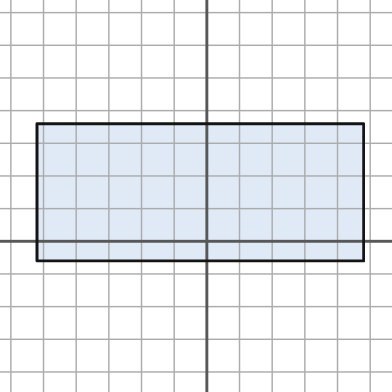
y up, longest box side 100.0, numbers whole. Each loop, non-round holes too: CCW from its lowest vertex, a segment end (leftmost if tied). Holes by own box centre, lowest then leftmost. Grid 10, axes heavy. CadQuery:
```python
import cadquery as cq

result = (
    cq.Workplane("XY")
    .moveTo(-52.0, -6.0)
    .lineTo(48.0, -6.0)
    .lineTo(48.0, 36.0)
    .lineTo(-52.0, 36.0)
    .close()
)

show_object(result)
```